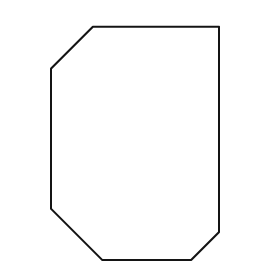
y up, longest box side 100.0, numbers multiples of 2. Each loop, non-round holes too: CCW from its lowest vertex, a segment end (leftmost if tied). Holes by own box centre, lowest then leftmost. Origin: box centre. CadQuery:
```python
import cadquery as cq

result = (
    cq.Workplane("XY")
    .moveTo(-14.0, -50.0)
    .lineTo(24.0, -50.0)
    .lineTo(36.0, -38.0)
    .lineTo(36.0, 50.0)
    .lineTo(-18.0, 50.0)
    .lineTo(-36.0, 32.0)
    .lineTo(-36.0, -28.0)
    .close()
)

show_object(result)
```